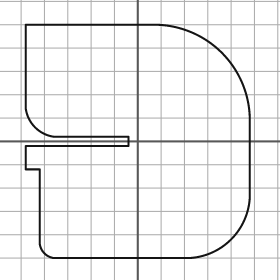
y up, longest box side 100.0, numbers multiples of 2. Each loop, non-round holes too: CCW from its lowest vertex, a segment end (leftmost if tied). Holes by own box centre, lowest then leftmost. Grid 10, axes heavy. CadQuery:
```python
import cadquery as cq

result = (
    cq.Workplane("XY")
    .moveTo(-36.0, -50.0)
    .lineTo(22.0, -50.0)
    .threePointArc((40.0, -42.0), (48.0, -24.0))
    .lineTo(48.0, 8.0)
    .threePointArc((36.0, 38.0), (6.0, 50.0))
    .lineTo(-48.0, 50.0)
    .lineTo(-48.0, 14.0)
    .threePointArc((-44.0, 6.0), (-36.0, 2.0))
    .lineTo(-4.0, 2.0)
    .lineTo(-4.0, -2.0)
    .lineTo(-48.0, -2.0)
    .lineTo(-48.0, -12.0)
    .lineTo(-42.0, -12.0)
    .lineTo(-42.0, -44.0)
    .threePointArc((-40.0, -48.0), (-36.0, -50.0))
    .close()
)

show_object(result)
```